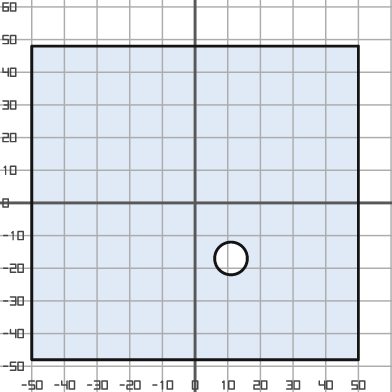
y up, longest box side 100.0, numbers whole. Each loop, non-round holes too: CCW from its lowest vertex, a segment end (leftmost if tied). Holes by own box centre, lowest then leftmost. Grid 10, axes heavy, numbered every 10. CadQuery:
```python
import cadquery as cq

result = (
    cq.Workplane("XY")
    .moveTo(-50.0, -48.0)
    .lineTo(50.0, -48.0)
    .lineTo(50.0, 48.0)
    .lineTo(-50.0, 48.0)
    .close()
    .moveTo(11.0, -17.0)
    .circle(5.0)
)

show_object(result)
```